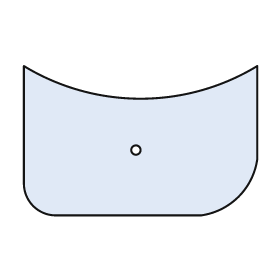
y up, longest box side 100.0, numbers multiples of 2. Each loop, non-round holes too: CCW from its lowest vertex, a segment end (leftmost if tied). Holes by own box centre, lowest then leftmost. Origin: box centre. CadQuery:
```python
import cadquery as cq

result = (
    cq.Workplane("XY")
    .moveTo(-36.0, -32.0)
    .lineTo(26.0, -32.0)
    .threePointArc((42.0, -24.0), (50.0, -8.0))
    .lineTo(50.0, 32.0)
    .threePointArc((0.0, 18.0), (-50.0, 32.0))
    .lineTo(-50.0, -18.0)
    .threePointArc((-46.0, -28.0), (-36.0, -32.0))
    .close()
    .moveTo(-2.0, -4.0)
    .circle(2.0)
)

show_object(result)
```